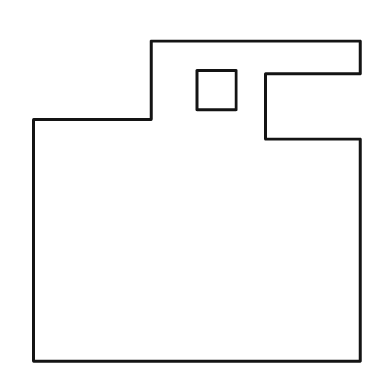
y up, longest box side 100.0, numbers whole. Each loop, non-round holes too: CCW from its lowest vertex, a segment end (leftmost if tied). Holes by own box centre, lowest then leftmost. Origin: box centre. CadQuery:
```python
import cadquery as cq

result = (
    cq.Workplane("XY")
    .moveTo(-50.0, -49.0)
    .lineTo(50.0, -49.0)
    .lineTo(50.0, 19.0)
    .lineTo(21.0, 19.0)
    .lineTo(21.0, 39.0)
    .lineTo(50.0, 39.0)
    .lineTo(50.0, 49.0)
    .lineTo(-14.0, 49.0)
    .lineTo(-14.0, 25.0)
    .lineTo(-50.0, 25.0)
    .close()
    .moveTo(0.0, 28.0)
    .lineTo(12.0, 28.0)
    .lineTo(12.0, 40.0)
    .lineTo(0.0, 40.0)
    .close()
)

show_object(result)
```